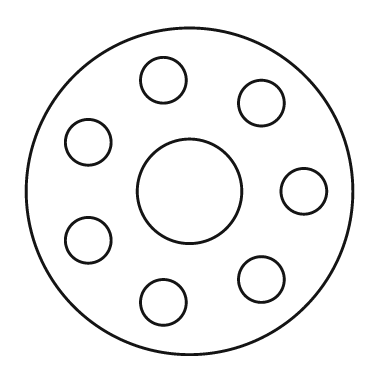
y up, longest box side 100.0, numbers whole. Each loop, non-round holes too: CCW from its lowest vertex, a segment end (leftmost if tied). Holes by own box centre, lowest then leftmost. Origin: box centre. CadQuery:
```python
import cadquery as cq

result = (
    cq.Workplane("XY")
    .moveTo(0.0, 0.0)
    .circle(50.0)
    .moveTo(-8.0, -34.0)
    .circle(7.0)
    .moveTo(22.0, -27.0)
    .circle(7.0)
    .moveTo(-31.0, -15.0)
    .circle(7.0)
    .moveTo(0.0, 0.0)
    .circle(16.0)
    .moveTo(35.0, 0.0)
    .circle(7.0)
    .moveTo(-31.0, 15.0)
    .circle(7.0)
    .moveTo(22.0, 27.0)
    .circle(7.0)
    .moveTo(-8.0, 34.0)
    .circle(7.0)
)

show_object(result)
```